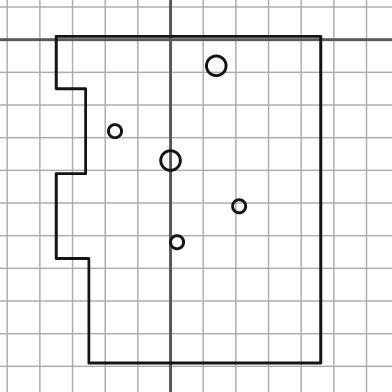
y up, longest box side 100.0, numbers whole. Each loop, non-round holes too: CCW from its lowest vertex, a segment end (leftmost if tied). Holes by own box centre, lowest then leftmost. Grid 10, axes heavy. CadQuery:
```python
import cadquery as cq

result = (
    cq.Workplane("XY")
    .moveTo(-25.0, -99.0)
    .lineTo(46.0, -99.0)
    .lineTo(46.0, 1.0)
    .lineTo(-35.0, 1.0)
    .lineTo(-35.0, -15.0)
    .lineTo(-26.0, -15.0)
    .lineTo(-26.0, -41.0)
    .lineTo(-35.0, -41.0)
    .lineTo(-35.0, -67.0)
    .lineTo(-25.0, -67.0)
    .close()
    .moveTo(2.0, -62.0)
    .circle(2.0)
    .moveTo(21.0, -51.0)
    .circle(2.0)
    .moveTo(0.0, -37.0)
    .circle(3.0)
    .moveTo(-17.0, -28.0)
    .circle(2.0)
    .moveTo(14.0, -8.0)
    .circle(3.0)
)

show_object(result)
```